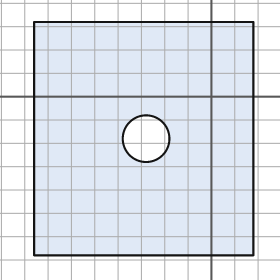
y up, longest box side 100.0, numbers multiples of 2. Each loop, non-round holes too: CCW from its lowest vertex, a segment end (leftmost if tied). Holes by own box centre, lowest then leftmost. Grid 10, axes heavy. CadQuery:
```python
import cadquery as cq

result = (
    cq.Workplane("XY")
    .moveTo(-76.0, -68.0)
    .lineTo(18.0, -68.0)
    .lineTo(18.0, 32.0)
    .lineTo(-76.0, 32.0)
    .close()
    .moveTo(-28.0, -18.0)
    .circle(10.0)
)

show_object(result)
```